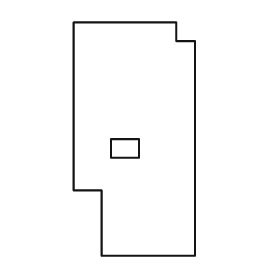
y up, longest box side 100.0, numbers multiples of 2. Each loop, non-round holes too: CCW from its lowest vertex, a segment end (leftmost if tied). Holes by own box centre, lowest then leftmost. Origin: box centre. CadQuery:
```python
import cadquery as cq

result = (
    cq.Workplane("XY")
    .moveTo(-14.0, -50.0)
    .lineTo(26.0, -50.0)
    .lineTo(26.0, 42.0)
    .lineTo(18.0, 42.0)
    .lineTo(18.0, 50.0)
    .lineTo(-26.0, 50.0)
    .lineTo(-26.0, -22.0)
    .lineTo(-14.0, -22.0)
    .close()
    .moveTo(-10.0, -8.0)
    .lineTo(2.0, -8.0)
    .lineTo(2.0, 0.0)
    .lineTo(-10.0, 0.0)
    .close()
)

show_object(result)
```